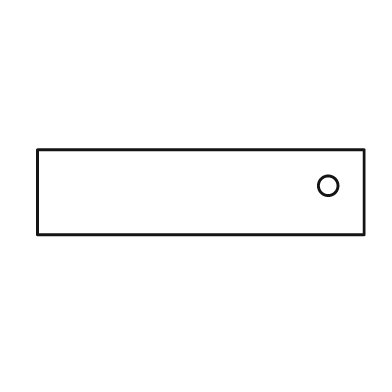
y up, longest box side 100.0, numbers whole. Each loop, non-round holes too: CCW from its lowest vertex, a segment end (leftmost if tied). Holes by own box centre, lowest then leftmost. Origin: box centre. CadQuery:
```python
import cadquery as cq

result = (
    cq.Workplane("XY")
    .moveTo(-50.0, -13.0)
    .lineTo(50.0, -13.0)
    .lineTo(50.0, 13.0)
    .lineTo(-50.0, 13.0)
    .close()
    .moveTo(39.0, 2.0)
    .circle(3.0)
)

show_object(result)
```